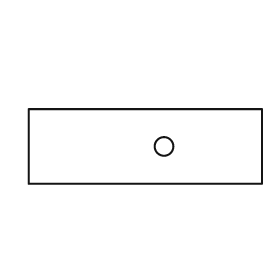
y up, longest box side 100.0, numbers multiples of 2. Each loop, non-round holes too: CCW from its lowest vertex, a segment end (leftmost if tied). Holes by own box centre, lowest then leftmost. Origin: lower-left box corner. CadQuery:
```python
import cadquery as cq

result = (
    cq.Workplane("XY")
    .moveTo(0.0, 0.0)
    .lineTo(100.0, 0.0)
    .lineTo(100.0, 32.0)
    .lineTo(0.0, 32.0)
    .close()
    .moveTo(58.0, 16.0)
    .circle(4.0)
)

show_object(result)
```